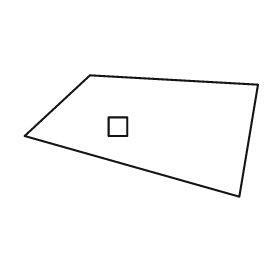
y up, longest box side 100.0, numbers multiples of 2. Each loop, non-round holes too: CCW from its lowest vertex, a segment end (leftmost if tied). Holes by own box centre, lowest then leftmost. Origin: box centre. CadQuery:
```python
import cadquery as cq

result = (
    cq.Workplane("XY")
    .moveTo(42.0, -26.0)
    .lineTo(50.0, 22.0)
    .lineTo(-22.0, 26.0)
    .lineTo(-50.0, 0.0)
    .close()
    .moveTo(-14.0, 0.0)
    .lineTo(-6.0, 0.0)
    .lineTo(-6.0, 8.0)
    .lineTo(-14.0, 8.0)
    .close()
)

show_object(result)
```